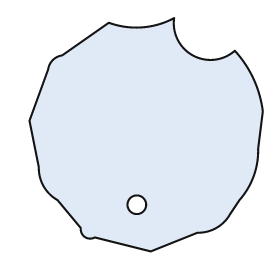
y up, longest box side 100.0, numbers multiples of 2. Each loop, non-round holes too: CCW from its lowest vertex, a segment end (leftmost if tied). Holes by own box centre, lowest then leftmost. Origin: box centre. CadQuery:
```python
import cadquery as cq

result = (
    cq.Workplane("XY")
    .moveTo(2.0, -50.0)
    .lineTo(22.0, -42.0)
    .threePointArc((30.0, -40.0), (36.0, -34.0))
    .lineTo(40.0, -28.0)
    .threePointArc((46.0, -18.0), (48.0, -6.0))
    .lineTo(50.0, 10.0)
    .threePointArc((46.0, 24.0), (38.0, 36.0))
    .threePointArc((20.0, 34.0), (12.0, 50.0))
    .threePointArc((-2.0, 46.0), (-16.0, 48.0))
    .lineTo(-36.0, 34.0)
    .threePointArc((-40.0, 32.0), (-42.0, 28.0))
    .lineTo(-50.0, 6.0)
    .lineTo(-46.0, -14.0)
    .threePointArc((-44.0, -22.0), (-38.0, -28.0))
    .lineTo(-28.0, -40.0)
    .threePointArc((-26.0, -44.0), (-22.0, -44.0))
    .close()
    .moveTo(-4.0, -30.0)
    .circle(4.0)
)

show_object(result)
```